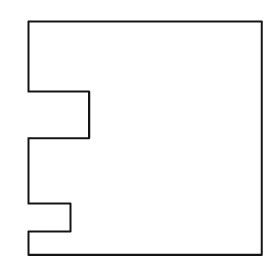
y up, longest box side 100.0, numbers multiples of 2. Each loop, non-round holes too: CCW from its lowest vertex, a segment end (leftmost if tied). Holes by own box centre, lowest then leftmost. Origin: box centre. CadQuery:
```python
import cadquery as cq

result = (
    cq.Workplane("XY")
    .moveTo(-50.0, -50.0)
    .lineTo(50.0, -50.0)
    .lineTo(50.0, 50.0)
    .lineTo(-50.0, 50.0)
    .lineTo(-50.0, 20.0)
    .lineTo(-24.0, 20.0)
    .lineTo(-24.0, 0.0)
    .lineTo(-50.0, 0.0)
    .lineTo(-50.0, -28.0)
    .lineTo(-32.0, -28.0)
    .lineTo(-32.0, -40.0)
    .lineTo(-50.0, -40.0)
    .close()
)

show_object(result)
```